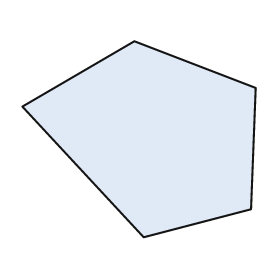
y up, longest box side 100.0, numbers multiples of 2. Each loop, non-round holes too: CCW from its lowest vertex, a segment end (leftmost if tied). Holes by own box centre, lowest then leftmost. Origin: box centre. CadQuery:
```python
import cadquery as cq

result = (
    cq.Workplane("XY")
    .moveTo(2.0, -42.0)
    .lineTo(48.0, -30.0)
    .lineTo(50.0, 22.0)
    .lineTo(-2.0, 42.0)
    .lineTo(-50.0, 14.0)
    .close()
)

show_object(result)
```